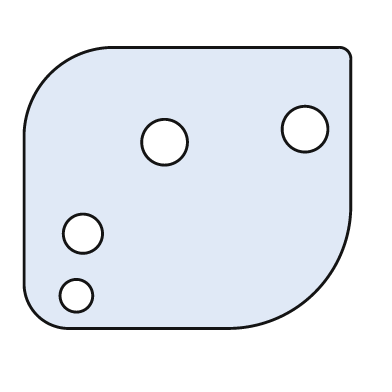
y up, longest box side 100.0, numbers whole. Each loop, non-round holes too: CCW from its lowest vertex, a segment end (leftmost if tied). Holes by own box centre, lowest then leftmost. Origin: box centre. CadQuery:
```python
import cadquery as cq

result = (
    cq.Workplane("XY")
    .moveTo(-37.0, -43.0)
    .lineTo(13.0, -43.0)
    .threePointArc((39.0, -32.0), (50.0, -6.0))
    .lineTo(50.0, 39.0)
    .threePointArc((49.0, 42.0), (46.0, 43.0))
    .lineTo(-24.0, 43.0)
    .threePointArc((-42.0, 35.0), (-50.0, 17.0))
    .lineTo(-50.0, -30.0)
    .threePointArc((-46.0, -39.0), (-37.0, -43.0))
    .close()
    .moveTo(-34.0, -33.0)
    .circle(5.0)
    .moveTo(-32.0, -14.0)
    .circle(6.0)
    .moveTo(-7.0, 14.0)
    .circle(7.0)
    .moveTo(36.0, 18.0)
    .circle(7.0)
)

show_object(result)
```